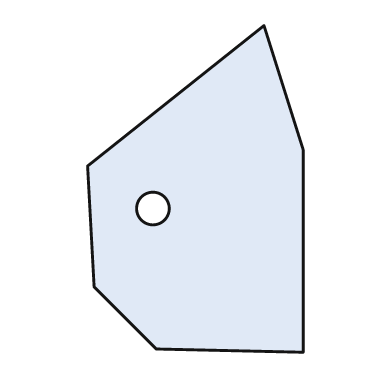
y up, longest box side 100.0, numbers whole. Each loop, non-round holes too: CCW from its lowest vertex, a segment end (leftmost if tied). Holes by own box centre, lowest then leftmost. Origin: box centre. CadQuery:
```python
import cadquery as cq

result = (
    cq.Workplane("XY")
    .moveTo(33.0, -50.0)
    .lineTo(33.0, 12.0)
    .lineTo(21.0, 50.0)
    .lineTo(-33.0, 7.0)
    .lineTo(-31.0, -30.0)
    .lineTo(-12.0, -49.0)
    .close()
    .moveTo(-13.0, -6.0)
    .circle(5.0)
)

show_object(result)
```